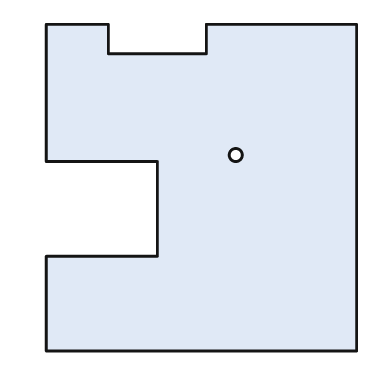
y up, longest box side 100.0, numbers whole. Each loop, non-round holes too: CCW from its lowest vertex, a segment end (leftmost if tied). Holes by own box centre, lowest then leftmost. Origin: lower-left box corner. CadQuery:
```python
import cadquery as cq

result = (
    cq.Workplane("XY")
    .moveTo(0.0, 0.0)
    .lineTo(95.0, 0.0)
    .lineTo(95.0, 100.0)
    .lineTo(49.0, 100.0)
    .lineTo(49.0, 91.0)
    .lineTo(19.0, 91.0)
    .lineTo(19.0, 100.0)
    .lineTo(0.0, 100.0)
    .lineTo(0.0, 58.0)
    .lineTo(34.0, 58.0)
    .lineTo(34.0, 29.0)
    .lineTo(0.0, 29.0)
    .close()
    .moveTo(58.0, 60.0)
    .circle(2.0)
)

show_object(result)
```